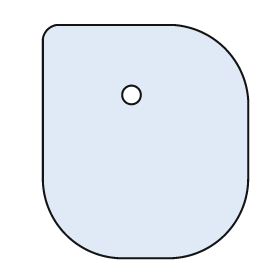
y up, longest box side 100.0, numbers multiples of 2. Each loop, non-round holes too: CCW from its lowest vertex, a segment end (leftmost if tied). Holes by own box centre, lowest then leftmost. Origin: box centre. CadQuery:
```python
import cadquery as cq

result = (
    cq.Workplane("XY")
    .moveTo(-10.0, -50.0)
    .lineTo(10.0, -50.0)
    .threePointArc((34.0, -40.0), (44.0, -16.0))
    .lineTo(44.0, 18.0)
    .threePointArc((34.0, 40.0), (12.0, 50.0))
    .lineTo(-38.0, 50.0)
    .threePointArc((-42.0, 48.0), (-44.0, 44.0))
    .lineTo(-44.0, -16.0)
    .threePointArc((-34.0, -40.0), (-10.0, -50.0))
    .close()
    .moveTo(-6.0, 20.0)
    .circle(4.0)
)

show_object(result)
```